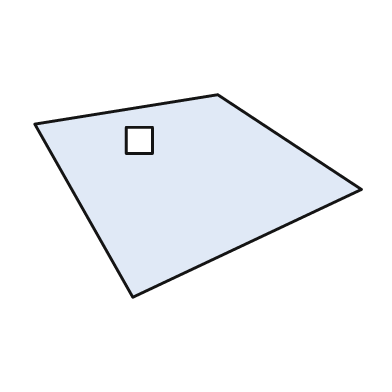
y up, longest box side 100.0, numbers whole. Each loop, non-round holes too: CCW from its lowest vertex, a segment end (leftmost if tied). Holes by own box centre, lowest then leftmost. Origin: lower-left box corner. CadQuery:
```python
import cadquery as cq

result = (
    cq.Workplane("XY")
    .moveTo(30.0, 0.0)
    .lineTo(100.0, 33.0)
    .lineTo(56.0, 62.0)
    .lineTo(0.0, 53.0)
    .close()
    .moveTo(28.0, 44.0)
    .lineTo(36.0, 44.0)
    .lineTo(36.0, 52.0)
    .lineTo(28.0, 52.0)
    .close()
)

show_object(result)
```